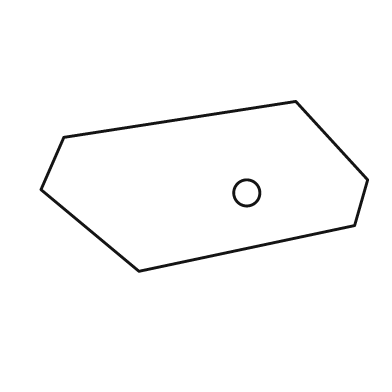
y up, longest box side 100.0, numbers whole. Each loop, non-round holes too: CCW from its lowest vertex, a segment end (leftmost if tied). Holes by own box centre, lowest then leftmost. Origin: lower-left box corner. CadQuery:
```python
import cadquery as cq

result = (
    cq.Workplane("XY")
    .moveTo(30.0, 0.0)
    .lineTo(96.0, 14.0)
    .lineTo(100.0, 28.0)
    .lineTo(78.0, 52.0)
    .lineTo(7.0, 41.0)
    .lineTo(0.0, 25.0)
    .close()
    .moveTo(63.0, 24.0)
    .circle(4.0)
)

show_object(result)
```